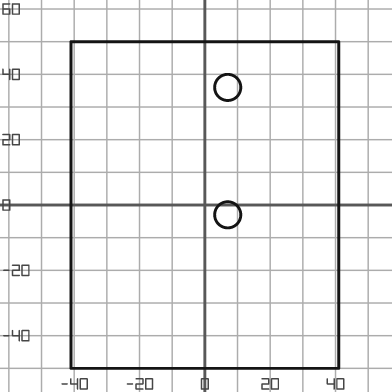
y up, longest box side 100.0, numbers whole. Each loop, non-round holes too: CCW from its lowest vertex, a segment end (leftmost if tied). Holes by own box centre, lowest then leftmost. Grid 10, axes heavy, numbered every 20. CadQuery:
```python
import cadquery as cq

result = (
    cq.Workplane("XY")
    .moveTo(-41.0, -50.0)
    .lineTo(41.0, -50.0)
    .lineTo(41.0, 50.0)
    .lineTo(-41.0, 50.0)
    .close()
    .moveTo(7.0, -3.0)
    .circle(4.0)
    .moveTo(7.0, 36.0)
    .circle(4.0)
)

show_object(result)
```